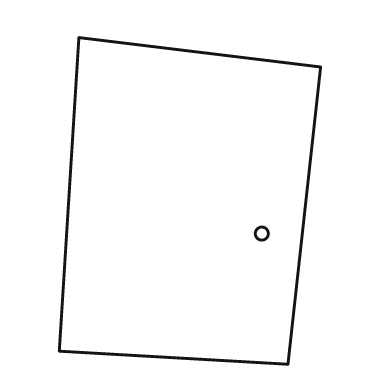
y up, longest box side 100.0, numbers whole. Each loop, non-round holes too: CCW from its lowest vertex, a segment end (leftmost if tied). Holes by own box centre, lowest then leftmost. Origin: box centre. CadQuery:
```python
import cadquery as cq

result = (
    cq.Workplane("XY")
    .moveTo(30.0, -50.0)
    .lineTo(40.0, 41.0)
    .lineTo(-34.0, 50.0)
    .lineTo(-40.0, -46.0)
    .close()
    .moveTo(22.0, -10.0)
    .circle(2.0)
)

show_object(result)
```